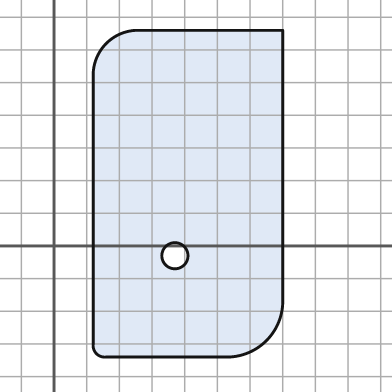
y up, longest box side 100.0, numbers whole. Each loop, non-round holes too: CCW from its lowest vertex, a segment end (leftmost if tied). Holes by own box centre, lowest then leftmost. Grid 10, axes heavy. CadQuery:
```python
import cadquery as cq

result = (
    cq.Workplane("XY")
    .moveTo(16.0, -34.0)
    .lineTo(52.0, -34.0)
    .threePointArc((65.0, -29.0), (70.0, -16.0))
    .lineTo(70.0, 66.0)
    .lineTo(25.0, 66.0)
    .threePointArc((16.0, 62.0), (12.0, 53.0))
    .lineTo(12.0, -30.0)
    .threePointArc((13.0, -33.0), (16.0, -34.0))
    .close()
    .moveTo(37.0, -3.0)
    .circle(4.0)
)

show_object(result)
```